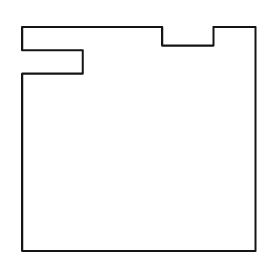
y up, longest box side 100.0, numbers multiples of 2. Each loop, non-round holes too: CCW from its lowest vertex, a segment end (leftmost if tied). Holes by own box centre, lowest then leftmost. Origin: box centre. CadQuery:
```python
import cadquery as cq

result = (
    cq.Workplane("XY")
    .moveTo(-50.0, -48.0)
    .lineTo(50.0, -48.0)
    .lineTo(50.0, 48.0)
    .lineTo(32.0, 48.0)
    .lineTo(32.0, 40.0)
    .lineTo(10.0, 40.0)
    .lineTo(10.0, 48.0)
    .lineTo(-50.0, 48.0)
    .lineTo(-50.0, 38.0)
    .lineTo(-24.0, 38.0)
    .lineTo(-24.0, 28.0)
    .lineTo(-50.0, 28.0)
    .close()
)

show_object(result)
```